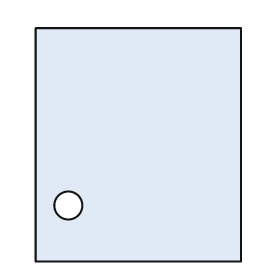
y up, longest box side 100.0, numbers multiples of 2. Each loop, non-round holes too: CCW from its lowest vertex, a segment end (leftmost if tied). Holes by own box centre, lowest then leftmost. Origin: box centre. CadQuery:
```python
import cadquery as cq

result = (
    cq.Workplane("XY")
    .moveTo(-44.0, -50.0)
    .lineTo(44.0, -50.0)
    .lineTo(44.0, 50.0)
    .lineTo(-44.0, 50.0)
    .close()
    .moveTo(-30.0, -26.0)
    .circle(6.0)
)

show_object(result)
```